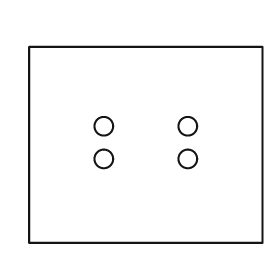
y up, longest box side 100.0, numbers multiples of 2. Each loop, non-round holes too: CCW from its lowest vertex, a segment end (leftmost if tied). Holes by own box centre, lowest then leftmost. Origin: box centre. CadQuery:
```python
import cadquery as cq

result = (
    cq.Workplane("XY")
    .moveTo(-50.0, -42.0)
    .lineTo(50.0, -42.0)
    .lineTo(50.0, 42.0)
    .lineTo(-50.0, 42.0)
    .close()
    .moveTo(-18.0, -6.0)
    .circle(4.0)
    .moveTo(18.0, -6.0)
    .circle(4.0)
    .moveTo(-18.0, 8.0)
    .circle(4.0)
    .moveTo(18.0, 8.0)
    .circle(4.0)
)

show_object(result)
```